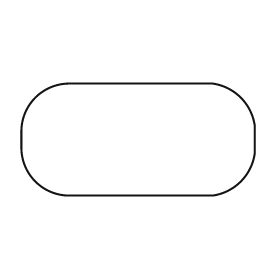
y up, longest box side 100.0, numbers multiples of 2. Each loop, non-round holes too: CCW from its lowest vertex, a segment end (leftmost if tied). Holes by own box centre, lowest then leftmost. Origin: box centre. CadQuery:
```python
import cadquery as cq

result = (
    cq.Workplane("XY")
    .moveTo(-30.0, -24.0)
    .lineTo(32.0, -24.0)
    .threePointArc((44.0, -18.0), (50.0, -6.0))
    .lineTo(50.0, 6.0)
    .threePointArc((44.0, 18.0), (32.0, 24.0))
    .lineTo(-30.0, 24.0)
    .threePointArc((-44.0, 18.0), (-50.0, 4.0))
    .lineTo(-50.0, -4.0)
    .threePointArc((-44.0, -18.0), (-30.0, -24.0))
    .close()
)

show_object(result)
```